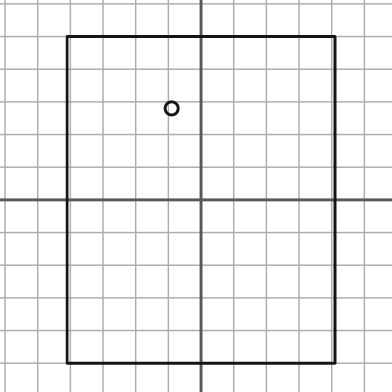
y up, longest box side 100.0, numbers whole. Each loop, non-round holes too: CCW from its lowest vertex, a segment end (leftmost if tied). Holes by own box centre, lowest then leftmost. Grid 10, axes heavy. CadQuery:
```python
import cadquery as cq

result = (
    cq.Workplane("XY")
    .moveTo(-41.0, -50.0)
    .lineTo(41.0, -50.0)
    .lineTo(41.0, 50.0)
    .lineTo(-41.0, 50.0)
    .close()
    .moveTo(-9.0, 28.0)
    .circle(2.0)
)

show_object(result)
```